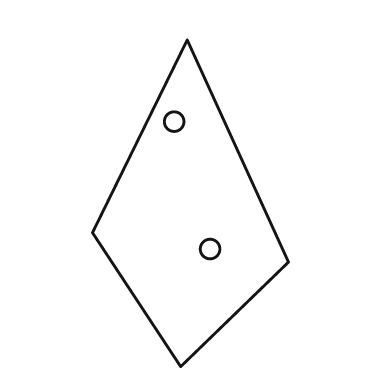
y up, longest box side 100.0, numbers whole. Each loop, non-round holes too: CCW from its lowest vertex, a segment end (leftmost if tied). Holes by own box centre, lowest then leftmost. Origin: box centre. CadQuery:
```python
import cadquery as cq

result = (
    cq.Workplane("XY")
    .moveTo(-3.0, -50.0)
    .lineTo(30.0, -18.0)
    .lineTo(-1.0, 50.0)
    .lineTo(-30.0, -9.0)
    .close()
    .moveTo(6.0, -14.0)
    .circle(3.0)
    .moveTo(-5.0, 25.0)
    .circle(3.0)
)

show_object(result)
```